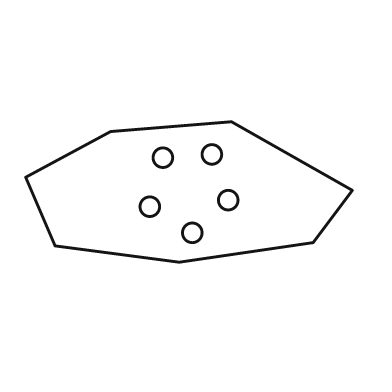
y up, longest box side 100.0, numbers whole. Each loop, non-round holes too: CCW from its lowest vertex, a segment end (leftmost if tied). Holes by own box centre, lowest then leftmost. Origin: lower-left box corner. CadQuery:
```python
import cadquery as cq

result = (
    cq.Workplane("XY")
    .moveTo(47.0, 0.0)
    .lineTo(88.0, 6.0)
    .lineTo(100.0, 22.0)
    .lineTo(63.0, 43.0)
    .lineTo(26.0, 40.0)
    .lineTo(0.0, 26.0)
    .lineTo(9.0, 5.0)
    .close()
    .moveTo(51.0, 9.0)
    .circle(3.0)
    .moveTo(38.0, 17.0)
    .circle(3.0)
    .moveTo(62.0, 19.0)
    .circle(3.0)
    .moveTo(42.0, 32.0)
    .circle(3.0)
    .moveTo(57.0, 33.0)
    .circle(3.0)
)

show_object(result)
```